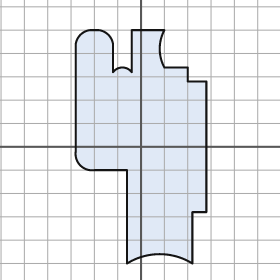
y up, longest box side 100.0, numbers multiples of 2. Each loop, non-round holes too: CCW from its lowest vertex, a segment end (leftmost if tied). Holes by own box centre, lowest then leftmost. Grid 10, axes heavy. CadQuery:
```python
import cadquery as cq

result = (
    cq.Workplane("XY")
    .moveTo(-6.0, -50.0)
    .threePointArc((8.0, -46.0), (22.0, -50.0))
    .lineTo(22.0, -28.0)
    .lineTo(28.0, -28.0)
    .lineTo(28.0, 28.0)
    .lineTo(20.0, 28.0)
    .lineTo(20.0, 34.0)
    .lineTo(10.0, 34.0)
    .threePointArc((8.0, 42.0), (10.0, 50.0))
    .lineTo(-4.0, 50.0)
    .lineTo(-4.0, 32.0)
    .threePointArc((-8.0, 34.0), (-12.0, 32.0))
    .lineTo(-12.0, 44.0)
    .threePointArc((-14.0, 48.0), (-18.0, 50.0))
    .lineTo(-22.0, 50.0)
    .threePointArc((-26.0, 48.0), (-28.0, 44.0))
    .lineTo(-28.0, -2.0)
    .threePointArc((-26.0, -8.0), (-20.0, -10.0))
    .lineTo(-6.0, -10.0)
    .close()
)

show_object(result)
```